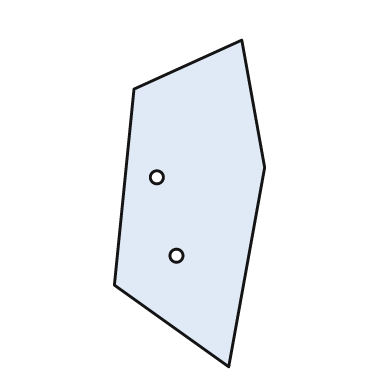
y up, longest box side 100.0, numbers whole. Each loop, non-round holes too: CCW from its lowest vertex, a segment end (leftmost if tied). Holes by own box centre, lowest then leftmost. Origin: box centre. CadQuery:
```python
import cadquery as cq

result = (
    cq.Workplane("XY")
    .moveTo(12.0, -50.0)
    .lineTo(23.0, 11.0)
    .lineTo(16.0, 50.0)
    .lineTo(-17.0, 35.0)
    .lineTo(-23.0, -25.0)
    .close()
    .moveTo(-4.0, -16.0)
    .circle(2.0)
    .moveTo(-10.0, 8.0)
    .circle(2.0)
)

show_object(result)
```